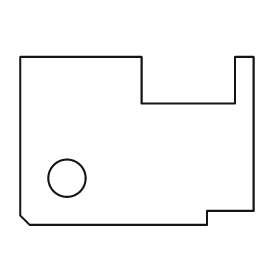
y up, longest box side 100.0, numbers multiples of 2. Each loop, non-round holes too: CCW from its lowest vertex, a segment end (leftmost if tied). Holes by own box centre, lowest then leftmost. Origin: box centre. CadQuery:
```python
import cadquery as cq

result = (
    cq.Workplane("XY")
    .moveTo(-46.0, -36.0)
    .lineTo(30.0, -36.0)
    .lineTo(30.0, -30.0)
    .lineTo(50.0, -30.0)
    .lineTo(50.0, 36.0)
    .lineTo(42.0, 36.0)
    .lineTo(42.0, 16.0)
    .lineTo(2.0, 16.0)
    .lineTo(2.0, 36.0)
    .lineTo(-50.0, 36.0)
    .lineTo(-50.0, -32.0)
    .close()
    .moveTo(-30.0, -16.0)
    .circle(8.0)
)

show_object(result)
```